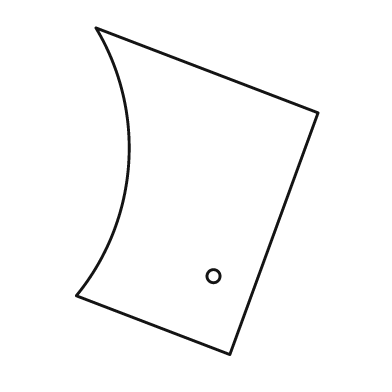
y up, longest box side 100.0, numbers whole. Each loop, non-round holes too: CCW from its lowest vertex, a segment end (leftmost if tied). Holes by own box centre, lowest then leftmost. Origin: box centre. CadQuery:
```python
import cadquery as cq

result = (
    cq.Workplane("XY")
    .moveTo(10.0, -50.0)
    .lineTo(37.0, 24.0)
    .lineTo(-31.0, 50.0)
    .threePointArc((-21.0, 8.0), (-37.0, -32.0))
    .close()
    .moveTo(5.0, -26.0)
    .circle(2.0)
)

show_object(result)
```